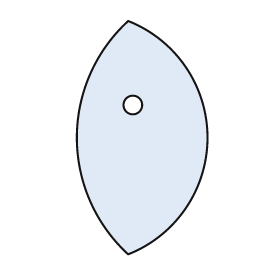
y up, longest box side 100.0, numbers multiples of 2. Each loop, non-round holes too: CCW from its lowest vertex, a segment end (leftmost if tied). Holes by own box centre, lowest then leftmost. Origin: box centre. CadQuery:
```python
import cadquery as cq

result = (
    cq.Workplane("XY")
    .moveTo(-6.0, -50.0)
    .threePointArc((28.0, 0.0), (-6.0, 50.0))
    .threePointArc((-28.0, 0.0), (-6.0, -50.0))
    .close()
    .moveTo(-4.0, 14.0)
    .circle(4.0)
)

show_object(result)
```